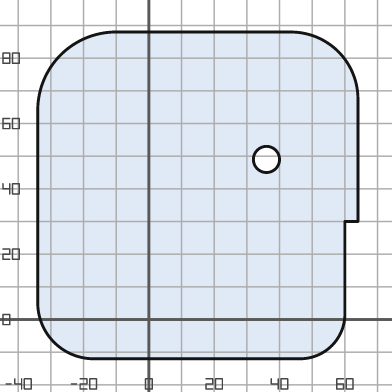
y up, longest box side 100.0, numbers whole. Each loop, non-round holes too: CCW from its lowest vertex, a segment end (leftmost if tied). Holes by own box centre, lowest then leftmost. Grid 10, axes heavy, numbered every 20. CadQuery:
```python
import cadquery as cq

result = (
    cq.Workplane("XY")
    .moveTo(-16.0, -12.0)
    .lineTo(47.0, -12.0)
    .threePointArc((56.0, -8.0), (60.0, 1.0))
    .lineTo(60.0, 30.0)
    .lineTo(64.0, 30.0)
    .lineTo(64.0, 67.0)
    .threePointArc((58.0, 82.0), (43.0, 88.0))
    .lineTo(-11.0, 88.0)
    .threePointArc((-27.0, 81.0), (-34.0, 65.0))
    .lineTo(-34.0, 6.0)
    .threePointArc((-29.0, -7.0), (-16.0, -12.0))
    .close()
    .moveTo(36.0, 49.0)
    .circle(4.0)
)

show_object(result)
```